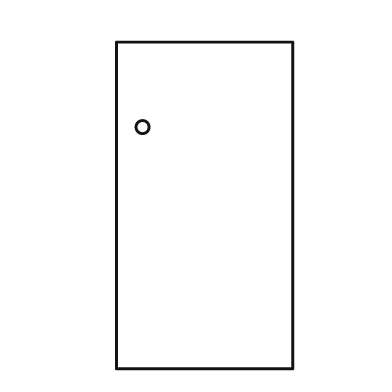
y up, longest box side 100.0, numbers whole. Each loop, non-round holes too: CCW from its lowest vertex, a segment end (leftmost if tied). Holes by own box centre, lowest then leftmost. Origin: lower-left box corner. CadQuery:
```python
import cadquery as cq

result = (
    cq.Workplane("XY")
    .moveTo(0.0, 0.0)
    .lineTo(54.0, 0.0)
    .lineTo(54.0, 100.0)
    .lineTo(0.0, 100.0)
    .close()
    .moveTo(8.0, 74.0)
    .circle(2.0)
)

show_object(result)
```